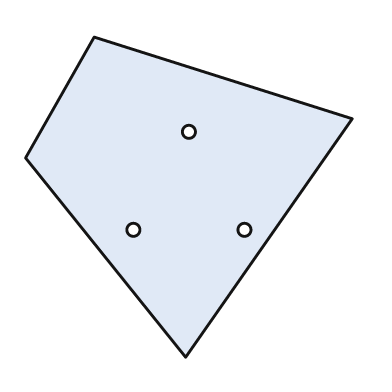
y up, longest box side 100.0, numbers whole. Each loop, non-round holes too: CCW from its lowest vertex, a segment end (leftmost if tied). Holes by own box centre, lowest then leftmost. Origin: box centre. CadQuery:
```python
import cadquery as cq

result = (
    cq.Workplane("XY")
    .moveTo(-1.0, -49.0)
    .lineTo(50.0, 24.0)
    .lineTo(-29.0, 49.0)
    .lineTo(-50.0, 12.0)
    .close()
    .moveTo(-17.0, -10.0)
    .circle(2.0)
    .moveTo(17.0, -10.0)
    .circle(2.0)
    .moveTo(0.0, 20.0)
    .circle(2.0)
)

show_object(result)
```